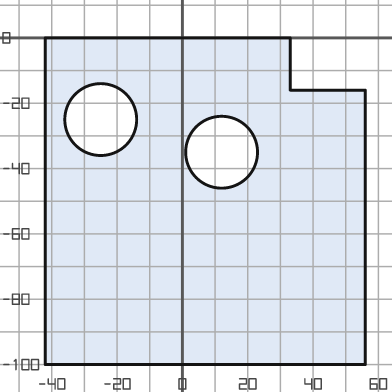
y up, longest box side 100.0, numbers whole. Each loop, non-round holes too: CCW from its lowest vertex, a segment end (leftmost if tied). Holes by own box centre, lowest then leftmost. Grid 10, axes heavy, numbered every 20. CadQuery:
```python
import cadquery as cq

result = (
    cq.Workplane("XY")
    .moveTo(-42.0, -100.0)
    .lineTo(56.0, -100.0)
    .lineTo(56.0, -16.0)
    .lineTo(33.0, -16.0)
    .lineTo(33.0, 0.0)
    .lineTo(-42.0, 0.0)
    .close()
    .moveTo(12.0, -35.0)
    .circle(11.0)
    .moveTo(-25.0, -25.0)
    .circle(11.0)
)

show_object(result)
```